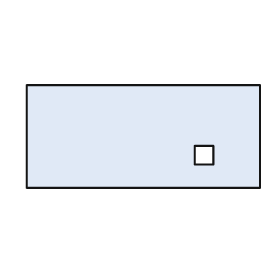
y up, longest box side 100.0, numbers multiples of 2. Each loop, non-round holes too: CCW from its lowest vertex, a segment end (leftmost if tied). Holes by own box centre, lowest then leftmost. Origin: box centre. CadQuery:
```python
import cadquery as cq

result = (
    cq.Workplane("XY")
    .moveTo(-50.0, -22.0)
    .lineTo(50.0, -22.0)
    .lineTo(50.0, 22.0)
    .lineTo(-50.0, 22.0)
    .close()
    .moveTo(22.0, -12.0)
    .lineTo(30.0, -12.0)
    .lineTo(30.0, -4.0)
    .lineTo(22.0, -4.0)
    .close()
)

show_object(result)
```